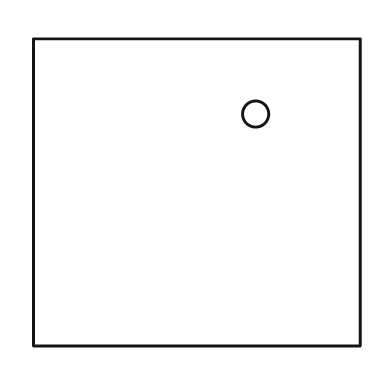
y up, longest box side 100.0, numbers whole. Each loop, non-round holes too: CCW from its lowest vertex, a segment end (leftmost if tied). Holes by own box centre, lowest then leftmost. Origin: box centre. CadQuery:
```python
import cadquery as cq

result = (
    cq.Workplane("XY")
    .moveTo(-50.0, -47.0)
    .lineTo(50.0, -47.0)
    .lineTo(50.0, 47.0)
    .lineTo(-50.0, 47.0)
    .close()
    .moveTo(18.0, 24.0)
    .circle(4.0)
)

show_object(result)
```